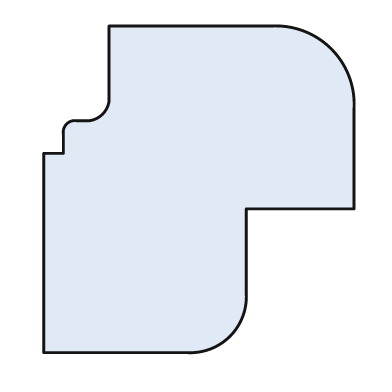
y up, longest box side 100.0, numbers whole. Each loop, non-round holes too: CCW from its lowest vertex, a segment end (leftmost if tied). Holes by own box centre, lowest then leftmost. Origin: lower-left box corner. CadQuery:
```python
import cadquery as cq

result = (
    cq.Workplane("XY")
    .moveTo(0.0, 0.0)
    .lineTo(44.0, 0.0)
    .threePointArc((57.0, 5.0), (62.0, 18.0))
    .lineTo(62.0, 44.0)
    .lineTo(95.0, 44.0)
    .lineTo(95.0, 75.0)
    .threePointArc((88.0, 93.0), (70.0, 100.0))
    .lineTo(20.0, 100.0)
    .lineTo(20.0, 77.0)
    .threePointArc((18.0, 73.0), (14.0, 71.0))
    .lineTo(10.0, 71.0)
    .threePointArc((7.0, 70.0), (6.0, 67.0))
    .lineTo(6.0, 61.0)
    .lineTo(0.0, 61.0)
    .close()
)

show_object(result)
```